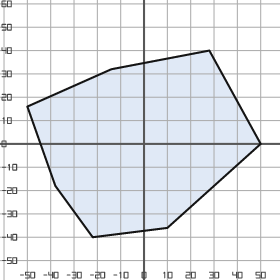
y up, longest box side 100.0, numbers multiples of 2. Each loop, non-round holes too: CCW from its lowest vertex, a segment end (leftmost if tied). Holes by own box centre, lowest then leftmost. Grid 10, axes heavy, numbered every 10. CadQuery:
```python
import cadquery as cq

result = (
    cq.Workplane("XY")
    .moveTo(-22.0, -40.0)
    .lineTo(10.0, -36.0)
    .lineTo(50.0, 0.0)
    .lineTo(28.0, 40.0)
    .lineTo(-14.0, 32.0)
    .lineTo(-50.0, 16.0)
    .lineTo(-38.0, -18.0)
    .close()
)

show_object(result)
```